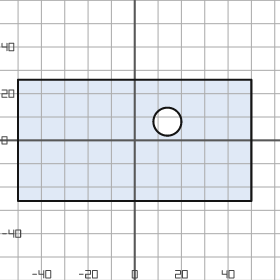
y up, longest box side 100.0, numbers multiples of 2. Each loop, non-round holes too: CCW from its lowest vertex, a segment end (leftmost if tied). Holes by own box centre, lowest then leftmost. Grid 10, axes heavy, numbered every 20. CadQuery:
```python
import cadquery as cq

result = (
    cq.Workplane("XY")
    .moveTo(-50.0, -26.0)
    .lineTo(50.0, -26.0)
    .lineTo(50.0, 26.0)
    .lineTo(-50.0, 26.0)
    .close()
    .moveTo(14.0, 8.0)
    .circle(6.0)
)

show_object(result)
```